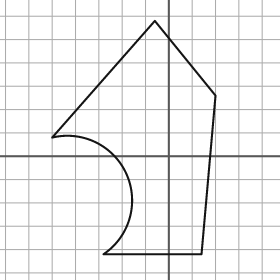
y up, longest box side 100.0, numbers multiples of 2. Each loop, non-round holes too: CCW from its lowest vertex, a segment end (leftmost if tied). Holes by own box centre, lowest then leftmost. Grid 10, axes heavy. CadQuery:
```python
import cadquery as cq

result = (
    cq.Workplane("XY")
    .moveTo(-28.0, -42.0)
    .lineTo(14.0, -42.0)
    .lineTo(20.0, 26.0)
    .lineTo(-6.0, 58.0)
    .lineTo(-50.0, 8.0)
    .threePointArc((-18.0, -8.0), (-28.0, -42.0))
    .close()
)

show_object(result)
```